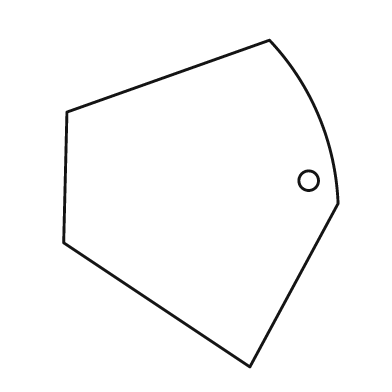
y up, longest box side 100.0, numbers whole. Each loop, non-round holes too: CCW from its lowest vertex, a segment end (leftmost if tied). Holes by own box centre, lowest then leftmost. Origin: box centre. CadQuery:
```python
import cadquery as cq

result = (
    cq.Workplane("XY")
    .moveTo(15.0, -50.0)
    .lineTo(42.0, 0.0)
    .threePointArc((36.0, 27.0), (21.0, 50.0))
    .lineTo(-41.0, 28.0)
    .lineTo(-42.0, -12.0)
    .close()
    .moveTo(33.0, 7.0)
    .circle(3.0)
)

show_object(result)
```